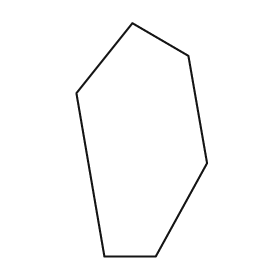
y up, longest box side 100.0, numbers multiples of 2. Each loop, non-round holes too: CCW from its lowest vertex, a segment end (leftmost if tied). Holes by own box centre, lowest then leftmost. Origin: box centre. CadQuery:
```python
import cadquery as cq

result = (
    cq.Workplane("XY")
    .moveTo(-16.0, -50.0)
    .lineTo(6.0, -50.0)
    .lineTo(28.0, -10.0)
    .lineTo(20.0, 36.0)
    .lineTo(-4.0, 50.0)
    .lineTo(-28.0, 20.0)
    .close()
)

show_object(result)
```